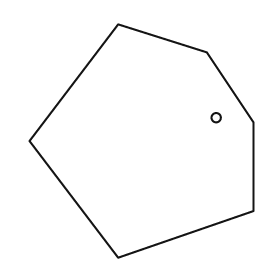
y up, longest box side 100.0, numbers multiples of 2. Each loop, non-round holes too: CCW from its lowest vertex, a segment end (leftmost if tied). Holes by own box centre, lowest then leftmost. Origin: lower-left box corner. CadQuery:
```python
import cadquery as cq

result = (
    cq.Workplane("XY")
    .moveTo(38.0, 0.0)
    .lineTo(96.0, 20.0)
    .lineTo(96.0, 58.0)
    .lineTo(76.0, 88.0)
    .lineTo(38.0, 100.0)
    .lineTo(0.0, 50.0)
    .close()
    .moveTo(80.0, 60.0)
    .circle(2.0)
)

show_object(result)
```